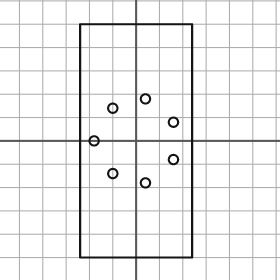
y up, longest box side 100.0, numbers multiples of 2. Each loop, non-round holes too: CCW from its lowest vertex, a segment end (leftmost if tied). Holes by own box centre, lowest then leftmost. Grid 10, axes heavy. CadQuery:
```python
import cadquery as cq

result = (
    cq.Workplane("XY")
    .moveTo(-24.0, -50.0)
    .lineTo(24.0, -50.0)
    .lineTo(24.0, 50.0)
    .lineTo(-24.0, 50.0)
    .close()
    .moveTo(4.0, -18.0)
    .circle(2.0)
    .moveTo(-10.0, -14.0)
    .circle(2.0)
    .moveTo(16.0, -8.0)
    .circle(2.0)
    .moveTo(-18.0, 0.0)
    .circle(2.0)
    .moveTo(16.0, 8.0)
    .circle(2.0)
    .moveTo(-10.0, 14.0)
    .circle(2.0)
    .moveTo(4.0, 18.0)
    .circle(2.0)
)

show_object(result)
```